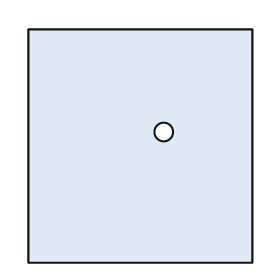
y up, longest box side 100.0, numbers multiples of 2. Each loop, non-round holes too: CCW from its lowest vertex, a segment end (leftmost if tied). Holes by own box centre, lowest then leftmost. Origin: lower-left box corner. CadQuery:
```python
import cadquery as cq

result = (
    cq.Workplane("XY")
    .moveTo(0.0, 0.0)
    .lineTo(96.0, 0.0)
    .lineTo(96.0, 100.0)
    .lineTo(0.0, 100.0)
    .close()
    .moveTo(58.0, 56.0)
    .circle(4.0)
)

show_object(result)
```